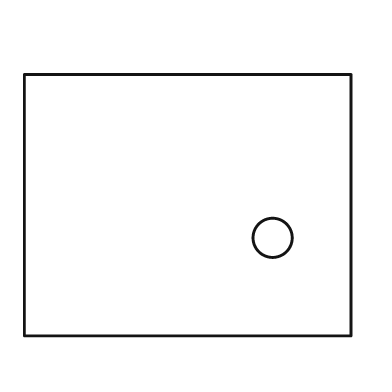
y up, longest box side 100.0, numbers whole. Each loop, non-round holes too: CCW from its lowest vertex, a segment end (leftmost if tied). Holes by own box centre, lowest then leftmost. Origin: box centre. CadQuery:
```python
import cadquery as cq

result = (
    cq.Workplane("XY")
    .moveTo(-50.0, -40.0)
    .lineTo(50.0, -40.0)
    .lineTo(50.0, 40.0)
    .lineTo(-50.0, 40.0)
    .close()
    .moveTo(26.0, -10.0)
    .circle(6.0)
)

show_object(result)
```